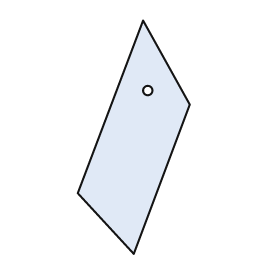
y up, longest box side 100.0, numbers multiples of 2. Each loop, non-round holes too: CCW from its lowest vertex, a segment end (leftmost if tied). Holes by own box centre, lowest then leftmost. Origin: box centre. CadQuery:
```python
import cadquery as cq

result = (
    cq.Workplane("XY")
    .moveTo(0.0, -50.0)
    .lineTo(24.0, 14.0)
    .lineTo(4.0, 50.0)
    .lineTo(-24.0, -24.0)
    .close()
    .moveTo(6.0, 20.0)
    .circle(2.0)
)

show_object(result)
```